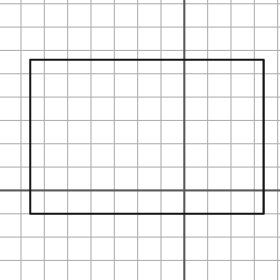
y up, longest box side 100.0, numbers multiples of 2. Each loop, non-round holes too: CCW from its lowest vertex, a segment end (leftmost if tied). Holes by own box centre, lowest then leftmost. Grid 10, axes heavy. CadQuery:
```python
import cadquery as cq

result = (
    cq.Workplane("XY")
    .moveTo(-66.0, -10.0)
    .lineTo(34.0, -10.0)
    .lineTo(34.0, 56.0)
    .lineTo(-66.0, 56.0)
    .close()
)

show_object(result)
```